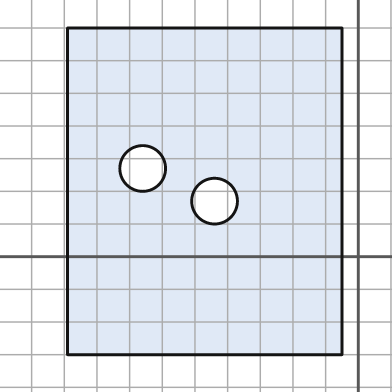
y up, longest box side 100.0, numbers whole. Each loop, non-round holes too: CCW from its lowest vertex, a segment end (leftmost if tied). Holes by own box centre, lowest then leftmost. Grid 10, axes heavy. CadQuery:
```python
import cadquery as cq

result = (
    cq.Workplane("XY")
    .moveTo(-89.0, -30.0)
    .lineTo(-5.0, -30.0)
    .lineTo(-5.0, 70.0)
    .lineTo(-89.0, 70.0)
    .close()
    .moveTo(-44.0, 17.0)
    .circle(7.0)
    .moveTo(-66.0, 27.0)
    .circle(7.0)
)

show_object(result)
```